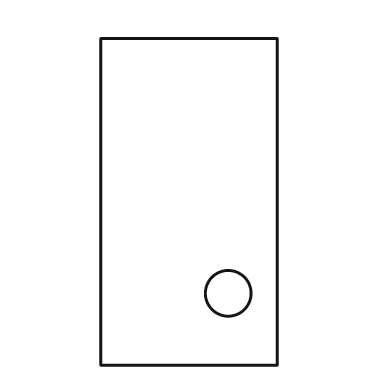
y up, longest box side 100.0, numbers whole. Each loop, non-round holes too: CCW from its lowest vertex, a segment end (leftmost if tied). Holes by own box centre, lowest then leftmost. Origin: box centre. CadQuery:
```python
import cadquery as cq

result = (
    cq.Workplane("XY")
    .moveTo(-27.0, -50.0)
    .lineTo(27.0, -50.0)
    .lineTo(27.0, 50.0)
    .lineTo(-27.0, 50.0)
    .close()
    .moveTo(12.0, -28.0)
    .circle(7.0)
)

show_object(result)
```